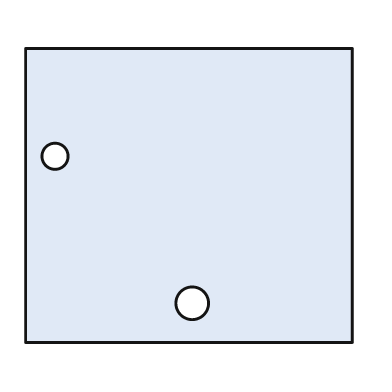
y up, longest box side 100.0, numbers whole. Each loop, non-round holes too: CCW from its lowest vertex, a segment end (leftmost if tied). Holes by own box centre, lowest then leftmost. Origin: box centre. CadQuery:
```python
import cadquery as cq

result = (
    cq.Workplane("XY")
    .moveTo(-50.0, -45.0)
    .lineTo(50.0, -45.0)
    .lineTo(50.0, 45.0)
    .lineTo(-50.0, 45.0)
    .close()
    .moveTo(1.0, -33.0)
    .circle(5.0)
    .moveTo(-41.0, 12.0)
    .circle(4.0)
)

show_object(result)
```